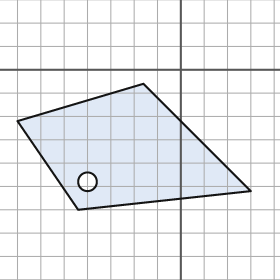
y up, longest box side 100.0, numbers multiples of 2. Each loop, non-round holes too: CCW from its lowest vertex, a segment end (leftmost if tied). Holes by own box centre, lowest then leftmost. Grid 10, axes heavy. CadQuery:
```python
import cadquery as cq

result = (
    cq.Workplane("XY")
    .moveTo(-44.0, -60.0)
    .lineTo(30.0, -52.0)
    .lineTo(-16.0, -6.0)
    .lineTo(-70.0, -22.0)
    .close()
    .moveTo(-40.0, -48.0)
    .circle(4.0)
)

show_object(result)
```